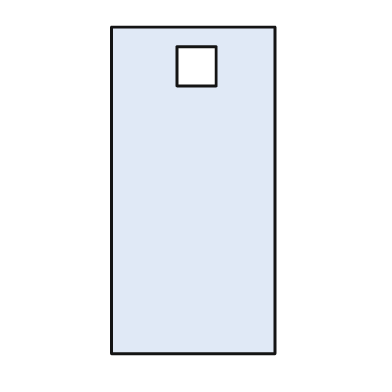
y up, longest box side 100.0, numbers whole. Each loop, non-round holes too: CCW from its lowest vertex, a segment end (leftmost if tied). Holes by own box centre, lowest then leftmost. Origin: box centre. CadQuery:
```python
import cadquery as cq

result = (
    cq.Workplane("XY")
    .moveTo(-25.0, -50.0)
    .lineTo(25.0, -50.0)
    .lineTo(25.0, 50.0)
    .lineTo(-25.0, 50.0)
    .close()
    .moveTo(-5.0, 32.0)
    .lineTo(7.0, 32.0)
    .lineTo(7.0, 44.0)
    .lineTo(-5.0, 44.0)
    .close()
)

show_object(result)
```